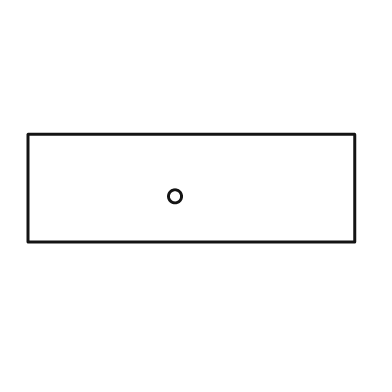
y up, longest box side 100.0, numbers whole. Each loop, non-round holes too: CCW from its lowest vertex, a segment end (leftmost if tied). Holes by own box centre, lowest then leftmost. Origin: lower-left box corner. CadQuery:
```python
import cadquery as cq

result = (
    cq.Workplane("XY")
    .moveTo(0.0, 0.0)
    .lineTo(100.0, 0.0)
    .lineTo(100.0, 33.0)
    .lineTo(0.0, 33.0)
    .close()
    .moveTo(45.0, 14.0)
    .circle(2.0)
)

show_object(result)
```